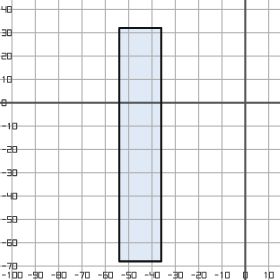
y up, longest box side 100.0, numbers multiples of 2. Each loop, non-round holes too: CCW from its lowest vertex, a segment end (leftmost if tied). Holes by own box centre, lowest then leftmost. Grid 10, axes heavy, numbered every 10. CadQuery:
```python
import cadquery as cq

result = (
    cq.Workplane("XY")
    .moveTo(-54.0, -68.0)
    .lineTo(-36.0, -68.0)
    .lineTo(-36.0, 32.0)
    .lineTo(-54.0, 32.0)
    .close()
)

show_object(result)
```